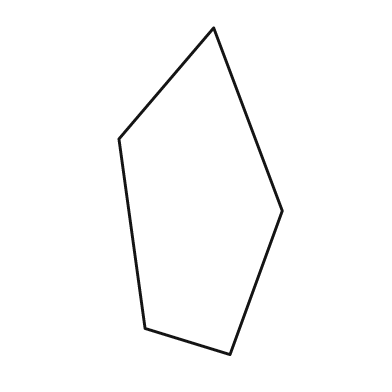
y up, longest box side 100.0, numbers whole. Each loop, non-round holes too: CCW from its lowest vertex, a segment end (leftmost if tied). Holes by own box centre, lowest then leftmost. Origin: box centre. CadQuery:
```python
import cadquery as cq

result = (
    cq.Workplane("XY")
    .moveTo(9.0, -50.0)
    .lineTo(25.0, -6.0)
    .lineTo(4.0, 50.0)
    .lineTo(-25.0, 16.0)
    .lineTo(-17.0, -42.0)
    .close()
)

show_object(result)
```